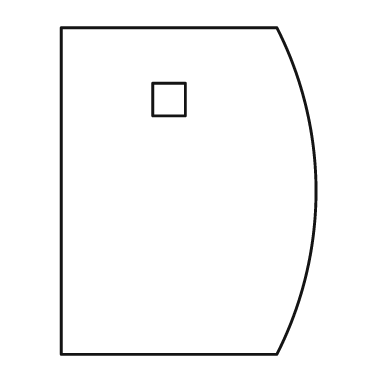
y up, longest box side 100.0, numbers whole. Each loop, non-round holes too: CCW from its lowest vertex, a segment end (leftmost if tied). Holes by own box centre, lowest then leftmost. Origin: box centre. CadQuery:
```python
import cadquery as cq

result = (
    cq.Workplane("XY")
    .moveTo(-39.0, -50.0)
    .lineTo(27.0, -50.0)
    .threePointArc((39.0, 0.0), (27.0, 50.0))
    .lineTo(-39.0, 50.0)
    .close()
    .moveTo(-11.0, 23.0)
    .lineTo(-1.0, 23.0)
    .lineTo(-1.0, 33.0)
    .lineTo(-11.0, 33.0)
    .close()
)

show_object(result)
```